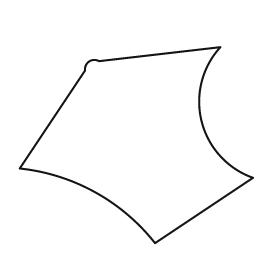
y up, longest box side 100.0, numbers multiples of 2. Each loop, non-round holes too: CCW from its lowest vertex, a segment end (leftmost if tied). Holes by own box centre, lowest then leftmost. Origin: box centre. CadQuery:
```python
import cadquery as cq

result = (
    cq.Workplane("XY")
    .moveTo(8.0, -42.0)
    .lineTo(50.0, -14.0)
    .threePointArc((28.0, 10.0), (36.0, 42.0))
    .lineTo(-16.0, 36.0)
    .threePointArc((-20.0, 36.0), (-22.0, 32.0))
    .lineTo(-50.0, -10.0)
    .threePointArc((-18.0, -20.0), (8.0, -42.0))
    .close()
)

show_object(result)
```